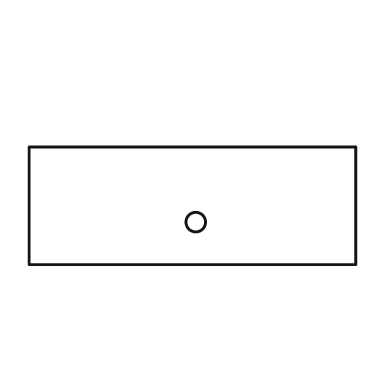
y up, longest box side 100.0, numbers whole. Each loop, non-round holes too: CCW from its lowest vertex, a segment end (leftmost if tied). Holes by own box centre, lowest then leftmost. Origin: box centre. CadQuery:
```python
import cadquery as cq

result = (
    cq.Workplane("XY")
    .moveTo(-50.0, -18.0)
    .lineTo(50.0, -18.0)
    .lineTo(50.0, 18.0)
    .lineTo(-50.0, 18.0)
    .close()
    .moveTo(1.0, -5.0)
    .circle(3.0)
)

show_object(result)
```